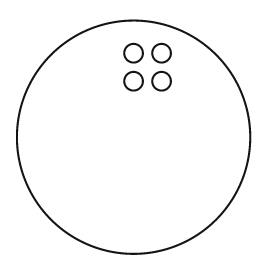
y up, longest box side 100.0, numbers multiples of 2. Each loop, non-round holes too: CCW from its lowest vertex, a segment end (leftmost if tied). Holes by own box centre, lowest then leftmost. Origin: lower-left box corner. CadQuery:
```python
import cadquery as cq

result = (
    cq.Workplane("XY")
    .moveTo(50.0, 50.0)
    .circle(50.0)
    .moveTo(50.0, 74.0)
    .circle(4.0)
    .moveTo(62.0, 74.0)
    .circle(4.0)
    .moveTo(50.0, 86.0)
    .circle(4.0)
    .moveTo(62.0, 86.0)
    .circle(4.0)
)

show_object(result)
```